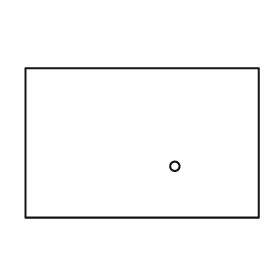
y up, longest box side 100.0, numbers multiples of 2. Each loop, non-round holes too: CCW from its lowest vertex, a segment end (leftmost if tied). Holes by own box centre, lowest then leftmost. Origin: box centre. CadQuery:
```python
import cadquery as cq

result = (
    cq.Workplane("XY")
    .moveTo(-50.0, -32.0)
    .lineTo(50.0, -32.0)
    .lineTo(50.0, 32.0)
    .lineTo(-50.0, 32.0)
    .close()
    .moveTo(14.0, -10.0)
    .circle(2.0)
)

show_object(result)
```